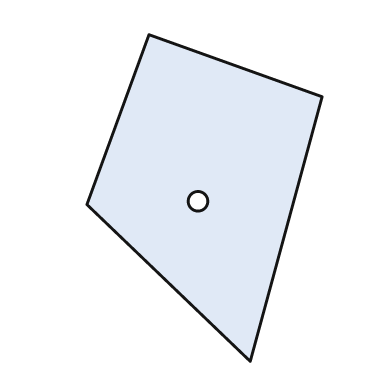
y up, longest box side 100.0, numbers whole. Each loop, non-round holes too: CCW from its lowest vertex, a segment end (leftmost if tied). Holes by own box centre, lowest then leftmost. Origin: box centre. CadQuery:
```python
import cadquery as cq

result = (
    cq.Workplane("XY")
    .moveTo(14.0, -50.0)
    .lineTo(36.0, 31.0)
    .lineTo(-17.0, 50.0)
    .lineTo(-36.0, -2.0)
    .close()
    .moveTo(-2.0, -1.0)
    .circle(3.0)
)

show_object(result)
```